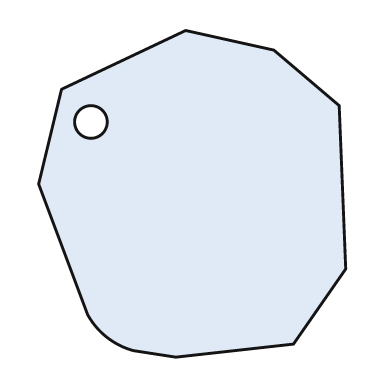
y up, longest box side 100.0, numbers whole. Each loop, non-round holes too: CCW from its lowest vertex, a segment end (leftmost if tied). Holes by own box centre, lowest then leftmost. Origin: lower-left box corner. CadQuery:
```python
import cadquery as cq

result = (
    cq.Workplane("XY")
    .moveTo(42.0, 0.0)
    .lineTo(78.0, 4.0)
    .lineTo(94.0, 27.0)
    .lineTo(92.0, 77.0)
    .lineTo(72.0, 94.0)
    .lineTo(45.0, 100.0)
    .lineTo(7.0, 82.0)
    .lineTo(0.0, 53.0)
    .lineTo(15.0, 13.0)
    .threePointArc((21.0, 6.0), (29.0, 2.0))
    .close()
    .moveTo(16.0, 72.0)
    .circle(5.0)
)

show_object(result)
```